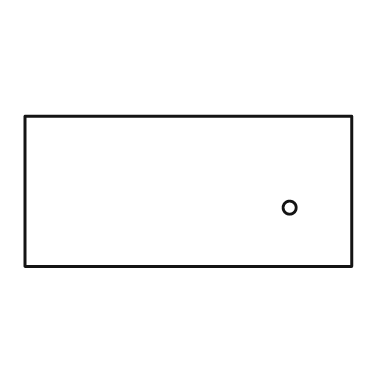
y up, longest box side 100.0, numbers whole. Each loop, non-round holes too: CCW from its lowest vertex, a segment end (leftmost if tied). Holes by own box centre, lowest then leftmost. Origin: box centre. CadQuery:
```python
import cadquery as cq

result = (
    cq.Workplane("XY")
    .moveTo(-50.0, -23.0)
    .lineTo(50.0, -23.0)
    .lineTo(50.0, 23.0)
    .lineTo(-50.0, 23.0)
    .close()
    .moveTo(31.0, -5.0)
    .circle(2.0)
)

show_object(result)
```